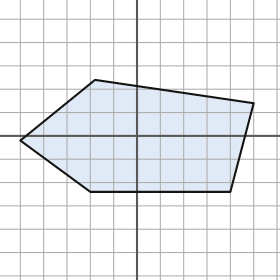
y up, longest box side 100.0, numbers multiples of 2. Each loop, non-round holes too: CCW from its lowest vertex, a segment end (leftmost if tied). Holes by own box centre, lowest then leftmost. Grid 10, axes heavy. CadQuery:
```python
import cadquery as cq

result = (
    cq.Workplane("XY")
    .moveTo(-20.0, -24.0)
    .lineTo(40.0, -24.0)
    .lineTo(50.0, 14.0)
    .lineTo(-18.0, 24.0)
    .lineTo(-50.0, -2.0)
    .close()
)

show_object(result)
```